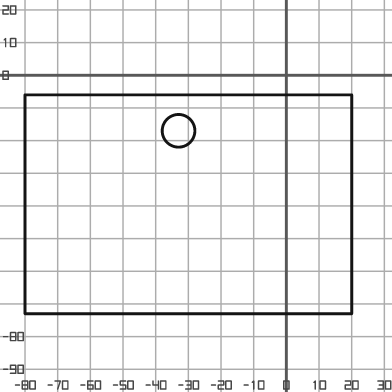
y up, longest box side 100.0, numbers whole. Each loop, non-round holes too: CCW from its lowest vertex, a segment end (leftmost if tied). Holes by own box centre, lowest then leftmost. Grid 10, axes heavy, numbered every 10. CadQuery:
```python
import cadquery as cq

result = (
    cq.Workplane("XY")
    .moveTo(-80.0, -73.0)
    .lineTo(20.0, -73.0)
    .lineTo(20.0, -6.0)
    .lineTo(-80.0, -6.0)
    .close()
    .moveTo(-33.0, -17.0)
    .circle(5.0)
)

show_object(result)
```